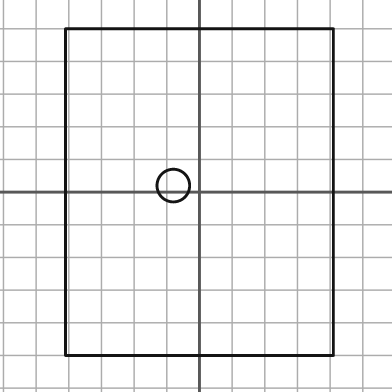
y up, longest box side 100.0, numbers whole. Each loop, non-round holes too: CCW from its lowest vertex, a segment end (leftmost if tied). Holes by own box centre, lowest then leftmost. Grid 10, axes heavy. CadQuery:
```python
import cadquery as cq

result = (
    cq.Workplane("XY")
    .moveTo(-41.0, -50.0)
    .lineTo(41.0, -50.0)
    .lineTo(41.0, 50.0)
    .lineTo(-41.0, 50.0)
    .close()
    .moveTo(-8.0, 2.0)
    .circle(5.0)
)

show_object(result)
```